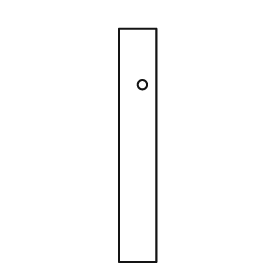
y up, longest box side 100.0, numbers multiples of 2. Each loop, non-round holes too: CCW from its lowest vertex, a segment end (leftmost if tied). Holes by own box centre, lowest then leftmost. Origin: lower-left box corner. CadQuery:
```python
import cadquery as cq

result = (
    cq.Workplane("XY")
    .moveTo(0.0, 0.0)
    .lineTo(16.0, 0.0)
    .lineTo(16.0, 100.0)
    .lineTo(0.0, 100.0)
    .close()
    .moveTo(10.0, 76.0)
    .circle(2.0)
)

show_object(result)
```